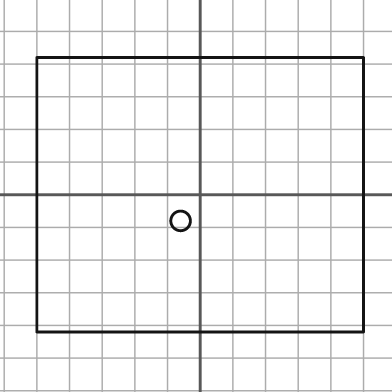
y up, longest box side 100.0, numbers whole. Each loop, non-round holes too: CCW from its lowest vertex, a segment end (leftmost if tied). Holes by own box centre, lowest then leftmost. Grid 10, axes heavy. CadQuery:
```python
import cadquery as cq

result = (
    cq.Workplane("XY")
    .moveTo(-50.0, -42.0)
    .lineTo(50.0, -42.0)
    .lineTo(50.0, 42.0)
    .lineTo(-50.0, 42.0)
    .close()
    .moveTo(-6.0, -8.0)
    .circle(3.0)
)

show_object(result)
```